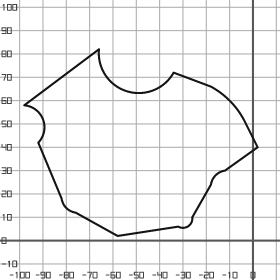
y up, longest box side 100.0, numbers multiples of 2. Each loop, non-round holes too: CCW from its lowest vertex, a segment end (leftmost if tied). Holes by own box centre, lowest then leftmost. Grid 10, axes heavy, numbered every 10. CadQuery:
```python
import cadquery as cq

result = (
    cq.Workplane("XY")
    .moveTo(-58.0, 2.0)
    .lineTo(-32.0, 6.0)
    .threePointArc((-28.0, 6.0), (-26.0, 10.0))
    .lineTo(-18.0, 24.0)
    .threePointArc((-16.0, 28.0), (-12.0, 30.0))
    .lineTo(2.0, 40.0)
    .lineTo(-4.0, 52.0)
    .threePointArc((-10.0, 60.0), (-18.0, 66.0))
    .lineTo(-34.0, 72.0)
    .threePointArc((-54.0, 64.0), (-66.0, 82.0))
    .lineTo(-98.0, 58.0)
    .threePointArc((-90.0, 52.0), (-92.0, 42.0))
    .lineTo(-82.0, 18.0)
    .threePointArc((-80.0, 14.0), (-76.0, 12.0))
    .close()
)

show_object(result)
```